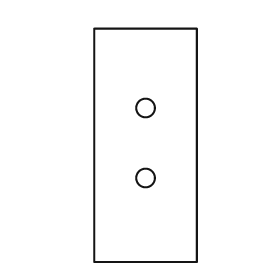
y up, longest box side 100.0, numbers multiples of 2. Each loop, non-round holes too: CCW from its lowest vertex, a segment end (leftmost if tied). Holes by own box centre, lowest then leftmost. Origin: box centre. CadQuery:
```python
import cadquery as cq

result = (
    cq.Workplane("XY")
    .moveTo(-22.0, -50.0)
    .lineTo(22.0, -50.0)
    .lineTo(22.0, 50.0)
    .lineTo(-22.0, 50.0)
    .close()
    .moveTo(0.0, -14.0)
    .circle(4.0)
    .moveTo(0.0, 16.0)
    .circle(4.0)
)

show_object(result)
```